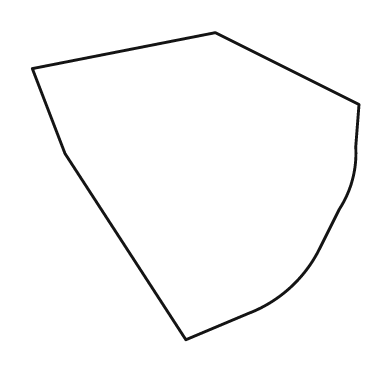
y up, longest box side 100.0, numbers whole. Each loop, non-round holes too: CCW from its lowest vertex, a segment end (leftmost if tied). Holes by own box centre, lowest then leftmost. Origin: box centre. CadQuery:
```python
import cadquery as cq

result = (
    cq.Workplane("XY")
    .moveTo(-3.0, -47.0)
    .lineTo(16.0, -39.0)
    .threePointArc((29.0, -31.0), (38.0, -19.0))
    .lineTo(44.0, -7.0)
    .threePointArc((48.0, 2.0), (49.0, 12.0))
    .lineTo(50.0, 25.0)
    .lineTo(6.0, 47.0)
    .lineTo(-50.0, 36.0)
    .lineTo(-40.0, 10.0)
    .close()
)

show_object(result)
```